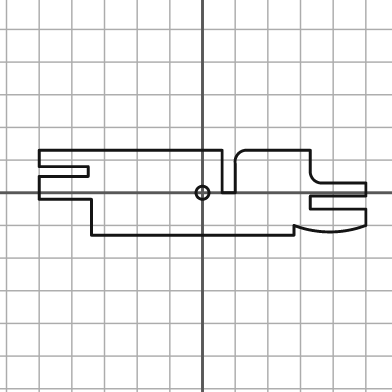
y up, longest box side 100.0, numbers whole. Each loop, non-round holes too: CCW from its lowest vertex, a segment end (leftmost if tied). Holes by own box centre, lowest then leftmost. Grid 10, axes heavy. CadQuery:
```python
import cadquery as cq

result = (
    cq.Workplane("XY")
    .moveTo(-34.0, -13.0)
    .lineTo(28.0, -13.0)
    .lineTo(28.0, -10.0)
    .threePointArc((39.0, -12.0), (50.0, -10.0))
    .lineTo(50.0, -5.0)
    .lineTo(33.0, -5.0)
    .lineTo(33.0, -1.0)
    .lineTo(50.0, -1.0)
    .lineTo(50.0, 3.0)
    .lineTo(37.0, 3.0)
    .threePointArc((34.0, 4.0), (33.0, 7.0))
    .lineTo(33.0, 13.0)
    .lineTo(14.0, 13.0)
    .threePointArc((11.0, 12.0), (10.0, 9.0))
    .lineTo(10.0, 0.0)
    .lineTo(6.0, 0.0)
    .lineTo(6.0, 13.0)
    .lineTo(-50.0, 13.0)
    .lineTo(-50.0, 8.0)
    .lineTo(-35.0, 8.0)
    .lineTo(-35.0, 5.0)
    .lineTo(-50.0, 5.0)
    .lineTo(-50.0, -2.0)
    .lineTo(-34.0, -2.0)
    .close()
    .moveTo(0.0, 0.0)
    .circle(2.0)
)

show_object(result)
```